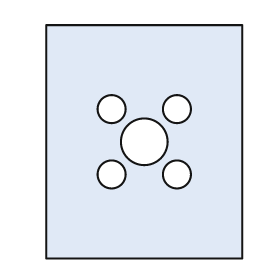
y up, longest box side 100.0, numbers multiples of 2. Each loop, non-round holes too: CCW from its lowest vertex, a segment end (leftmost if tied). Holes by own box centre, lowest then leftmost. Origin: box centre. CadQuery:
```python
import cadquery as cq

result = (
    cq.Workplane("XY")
    .moveTo(-42.0, -50.0)
    .lineTo(42.0, -50.0)
    .lineTo(42.0, 50.0)
    .lineTo(-42.0, 50.0)
    .close()
    .moveTo(-14.0, -14.0)
    .circle(6.0)
    .moveTo(14.0, -14.0)
    .circle(6.0)
    .moveTo(0.0, 0.0)
    .circle(10.0)
    .moveTo(-14.0, 14.0)
    .circle(6.0)
    .moveTo(14.0, 14.0)
    .circle(6.0)
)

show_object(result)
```